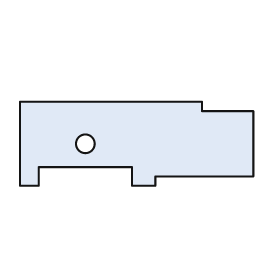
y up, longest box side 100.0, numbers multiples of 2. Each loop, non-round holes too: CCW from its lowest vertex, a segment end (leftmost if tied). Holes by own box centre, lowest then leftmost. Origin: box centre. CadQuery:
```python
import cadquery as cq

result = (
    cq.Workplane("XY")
    .moveTo(-50.0, -18.0)
    .lineTo(-42.0, -18.0)
    .lineTo(-42.0, -10.0)
    .lineTo(-2.0, -10.0)
    .lineTo(-2.0, -18.0)
    .lineTo(8.0, -18.0)
    .lineTo(8.0, -14.0)
    .lineTo(50.0, -14.0)
    .lineTo(50.0, 14.0)
    .lineTo(28.0, 14.0)
    .lineTo(28.0, 18.0)
    .lineTo(-50.0, 18.0)
    .close()
    .moveTo(-22.0, 0.0)
    .circle(4.0)
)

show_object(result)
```